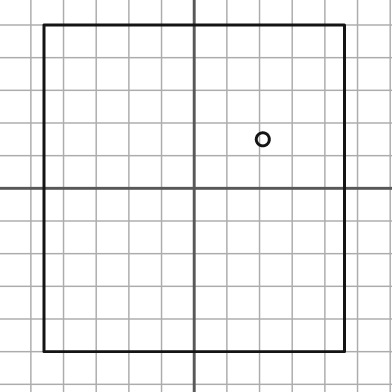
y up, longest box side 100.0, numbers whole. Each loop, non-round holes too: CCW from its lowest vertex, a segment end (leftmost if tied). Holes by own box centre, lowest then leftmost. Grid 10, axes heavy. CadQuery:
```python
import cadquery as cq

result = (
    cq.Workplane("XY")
    .moveTo(-46.0, -50.0)
    .lineTo(46.0, -50.0)
    .lineTo(46.0, 50.0)
    .lineTo(-46.0, 50.0)
    .close()
    .moveTo(21.0, 15.0)
    .circle(2.0)
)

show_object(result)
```